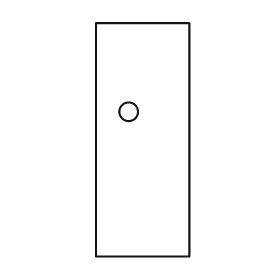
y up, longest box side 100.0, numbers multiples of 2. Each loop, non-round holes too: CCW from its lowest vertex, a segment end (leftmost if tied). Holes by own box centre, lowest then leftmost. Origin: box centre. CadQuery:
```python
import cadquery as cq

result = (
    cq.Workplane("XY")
    .moveTo(-20.0, -50.0)
    .lineTo(20.0, -50.0)
    .lineTo(20.0, 50.0)
    .lineTo(-20.0, 50.0)
    .close()
    .moveTo(-6.0, 12.0)
    .circle(4.0)
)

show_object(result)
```